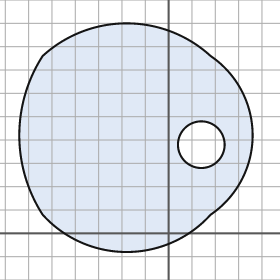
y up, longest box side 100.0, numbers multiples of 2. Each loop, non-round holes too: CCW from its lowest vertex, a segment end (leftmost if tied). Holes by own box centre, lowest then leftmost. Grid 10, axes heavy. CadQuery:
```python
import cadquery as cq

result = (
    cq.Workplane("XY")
    .moveTo(-54.0, 8.0)
    .threePointArc((-18.0, -8.0), (18.0, 8.0))
    .threePointArc((36.0, 42.0), (18.0, 76.0))
    .threePointArc((-18.0, 90.0), (-54.0, 76.0))
    .threePointArc((-64.0, 42.0), (-54.0, 8.0))
    .close()
    .moveTo(14.0, 38.0)
    .circle(10.0)
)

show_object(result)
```